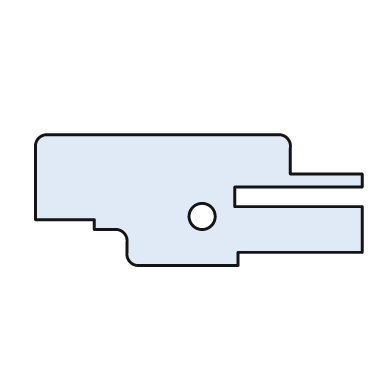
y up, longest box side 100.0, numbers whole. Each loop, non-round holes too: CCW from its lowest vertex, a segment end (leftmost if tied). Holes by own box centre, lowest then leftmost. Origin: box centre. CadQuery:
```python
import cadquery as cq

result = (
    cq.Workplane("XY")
    .moveTo(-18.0, -20.0)
    .lineTo(12.0, -20.0)
    .lineTo(12.0, -16.0)
    .lineTo(50.0, -16.0)
    .lineTo(50.0, -2.0)
    .lineTo(11.0, -2.0)
    .lineTo(11.0, 4.0)
    .lineTo(50.0, 4.0)
    .lineTo(50.0, 8.0)
    .lineTo(28.0, 8.0)
    .lineTo(28.0, 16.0)
    .threePointArc((27.0, 19.0), (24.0, 20.0))
    .lineTo(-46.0, 20.0)
    .threePointArc((-49.0, 19.0), (-50.0, 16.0))
    .lineTo(-50.0, -6.0)
    .lineTo(-32.0, -6.0)
    .lineTo(-32.0, -9.0)
    .lineTo(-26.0, -9.0)
    .threePointArc((-23.0, -10.0), (-22.0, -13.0))
    .lineTo(-22.0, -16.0)
    .threePointArc((-21.0, -19.0), (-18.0, -20.0))
    .close()
    .moveTo(1.0, -5.0)
    .circle(4.0)
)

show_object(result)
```